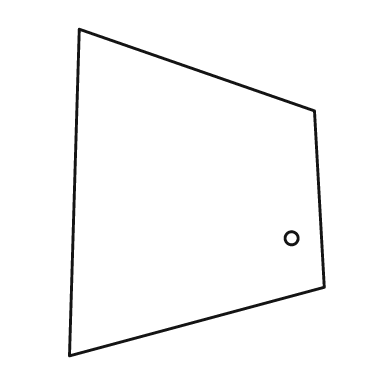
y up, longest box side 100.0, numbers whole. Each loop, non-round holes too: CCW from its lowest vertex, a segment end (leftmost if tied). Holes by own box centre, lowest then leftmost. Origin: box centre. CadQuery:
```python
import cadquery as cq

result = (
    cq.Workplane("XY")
    .moveTo(-39.0, -50.0)
    .lineTo(39.0, -29.0)
    .lineTo(36.0, 25.0)
    .lineTo(-36.0, 50.0)
    .close()
    .moveTo(29.0, -14.0)
    .circle(2.0)
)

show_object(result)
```